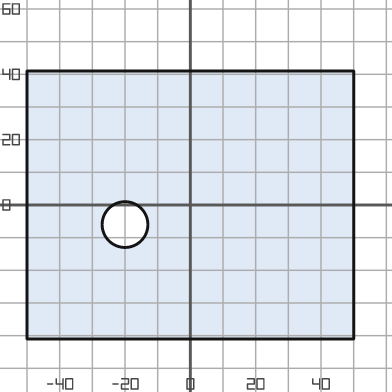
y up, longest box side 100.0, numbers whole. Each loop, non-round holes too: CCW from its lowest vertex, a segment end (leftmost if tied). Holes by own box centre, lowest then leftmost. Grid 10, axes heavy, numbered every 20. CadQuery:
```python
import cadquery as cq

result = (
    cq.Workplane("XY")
    .moveTo(-50.0, -41.0)
    .lineTo(50.0, -41.0)
    .lineTo(50.0, 41.0)
    .lineTo(-50.0, 41.0)
    .close()
    .moveTo(-20.0, -6.0)
    .circle(7.0)
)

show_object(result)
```